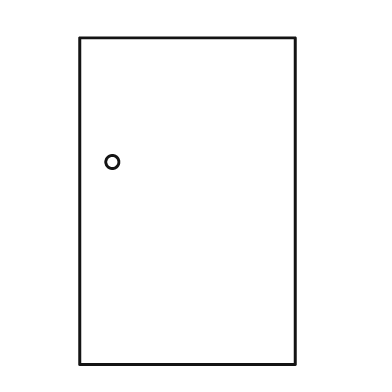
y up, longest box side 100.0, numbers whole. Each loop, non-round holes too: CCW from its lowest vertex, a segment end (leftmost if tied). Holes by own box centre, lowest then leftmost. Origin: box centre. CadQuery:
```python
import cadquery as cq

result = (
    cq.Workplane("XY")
    .moveTo(-33.0, -50.0)
    .lineTo(33.0, -50.0)
    .lineTo(33.0, 50.0)
    .lineTo(-33.0, 50.0)
    .close()
    .moveTo(-23.0, 12.0)
    .circle(2.0)
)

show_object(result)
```